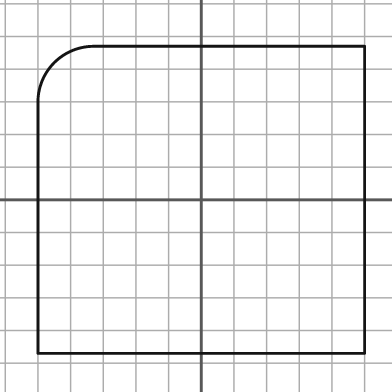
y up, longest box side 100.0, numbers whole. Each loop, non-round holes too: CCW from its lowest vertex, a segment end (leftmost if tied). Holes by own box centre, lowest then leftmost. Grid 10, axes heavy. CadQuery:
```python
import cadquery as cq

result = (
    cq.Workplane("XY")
    .moveTo(-50.0, -47.0)
    .lineTo(50.0, -47.0)
    .lineTo(50.0, 47.0)
    .lineTo(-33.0, 47.0)
    .threePointArc((-45.0, 42.0), (-50.0, 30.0))
    .close()
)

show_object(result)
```